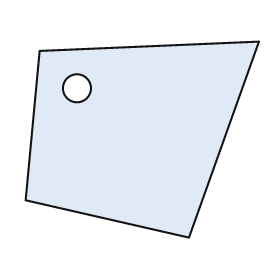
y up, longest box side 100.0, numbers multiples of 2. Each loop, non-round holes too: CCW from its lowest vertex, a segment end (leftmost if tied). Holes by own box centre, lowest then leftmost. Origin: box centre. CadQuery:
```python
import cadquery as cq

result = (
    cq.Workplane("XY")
    .moveTo(20.0, -42.0)
    .lineTo(50.0, 42.0)
    .lineTo(-44.0, 38.0)
    .lineTo(-50.0, -26.0)
    .close()
    .moveTo(-28.0, 22.0)
    .circle(6.0)
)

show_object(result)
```